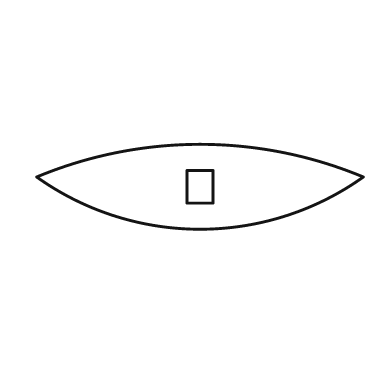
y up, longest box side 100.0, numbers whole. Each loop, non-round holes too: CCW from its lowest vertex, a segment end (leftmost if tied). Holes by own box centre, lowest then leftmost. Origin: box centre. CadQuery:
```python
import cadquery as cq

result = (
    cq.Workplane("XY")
    .moveTo(-50.0, 3.0)
    .threePointArc((0.0, -13.0), (50.0, 3.0))
    .threePointArc((0.0, 13.0), (-50.0, 3.0))
    .close()
    .moveTo(-4.0, -5.0)
    .lineTo(4.0, -5.0)
    .lineTo(4.0, 5.0)
    .lineTo(-4.0, 5.0)
    .close()
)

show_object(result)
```